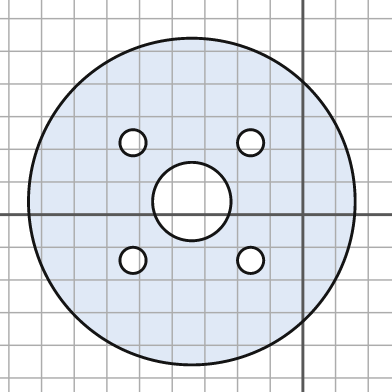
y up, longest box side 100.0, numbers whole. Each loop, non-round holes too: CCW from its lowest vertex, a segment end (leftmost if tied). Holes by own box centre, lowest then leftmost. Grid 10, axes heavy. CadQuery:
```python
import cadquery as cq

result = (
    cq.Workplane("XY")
    .moveTo(-34.0, 4.0)
    .circle(50.0)
    .moveTo(-52.0, -14.0)
    .circle(4.0)
    .moveTo(-16.0, -14.0)
    .circle(4.0)
    .moveTo(-34.0, 4.0)
    .circle(12.0)
    .moveTo(-52.0, 22.0)
    .circle(4.0)
    .moveTo(-16.0, 22.0)
    .circle(4.0)
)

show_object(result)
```